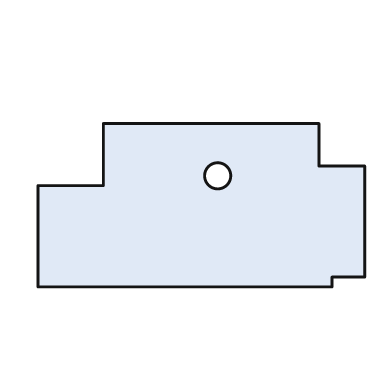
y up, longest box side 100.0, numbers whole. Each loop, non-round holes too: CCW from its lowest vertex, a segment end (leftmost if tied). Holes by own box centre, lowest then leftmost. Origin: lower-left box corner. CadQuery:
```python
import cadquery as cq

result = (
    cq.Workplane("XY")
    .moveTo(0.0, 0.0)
    .lineTo(90.0, 0.0)
    .lineTo(90.0, 3.0)
    .lineTo(100.0, 3.0)
    .lineTo(100.0, 37.0)
    .lineTo(86.0, 37.0)
    .lineTo(86.0, 50.0)
    .lineTo(20.0, 50.0)
    .lineTo(20.0, 31.0)
    .lineTo(0.0, 31.0)
    .close()
    .moveTo(55.0, 34.0)
    .circle(4.0)
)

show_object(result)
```